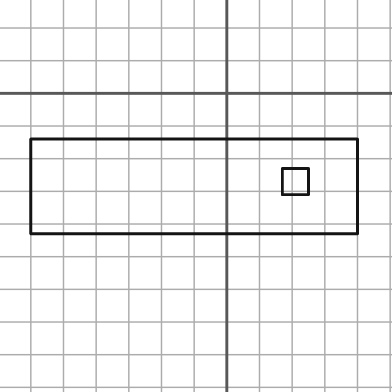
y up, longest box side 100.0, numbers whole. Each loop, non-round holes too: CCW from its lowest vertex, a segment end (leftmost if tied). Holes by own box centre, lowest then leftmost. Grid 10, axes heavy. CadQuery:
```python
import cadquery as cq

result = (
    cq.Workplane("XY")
    .moveTo(-60.0, -43.0)
    .lineTo(40.0, -43.0)
    .lineTo(40.0, -14.0)
    .lineTo(-60.0, -14.0)
    .close()
    .moveTo(17.0, -31.0)
    .lineTo(25.0, -31.0)
    .lineTo(25.0, -23.0)
    .lineTo(17.0, -23.0)
    .close()
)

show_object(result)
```